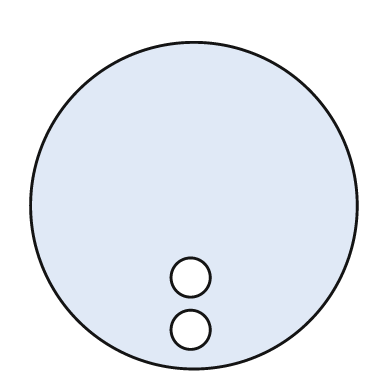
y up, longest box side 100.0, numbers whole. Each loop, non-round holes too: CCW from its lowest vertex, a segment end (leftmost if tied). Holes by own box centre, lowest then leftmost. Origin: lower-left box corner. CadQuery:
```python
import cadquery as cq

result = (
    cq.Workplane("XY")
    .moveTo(50.0, 50.0)
    .circle(50.0)
    .moveTo(49.0, 12.0)
    .circle(6.0)
    .moveTo(49.0, 28.0)
    .circle(6.0)
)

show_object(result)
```